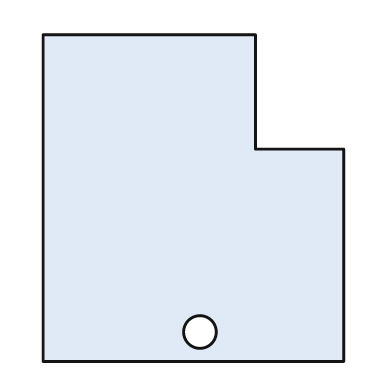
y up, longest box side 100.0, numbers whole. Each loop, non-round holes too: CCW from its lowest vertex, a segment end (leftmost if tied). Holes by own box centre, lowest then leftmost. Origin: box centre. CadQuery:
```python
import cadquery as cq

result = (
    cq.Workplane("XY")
    .moveTo(-46.0, -50.0)
    .lineTo(46.0, -50.0)
    .lineTo(46.0, 15.0)
    .lineTo(19.0, 15.0)
    .lineTo(19.0, 50.0)
    .lineTo(-46.0, 50.0)
    .close()
    .moveTo(2.0, -41.0)
    .circle(5.0)
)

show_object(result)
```